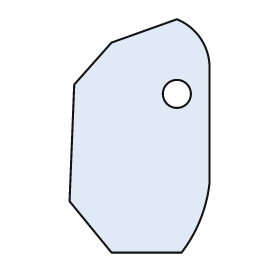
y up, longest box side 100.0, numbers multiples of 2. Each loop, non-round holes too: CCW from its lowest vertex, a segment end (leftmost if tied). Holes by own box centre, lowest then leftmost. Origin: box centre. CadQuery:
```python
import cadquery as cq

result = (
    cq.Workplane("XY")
    .moveTo(-12.0, -50.0)
    .lineTo(18.0, -50.0)
    .threePointArc((26.0, -36.0), (30.0, -20.0))
    .lineTo(30.0, 30.0)
    .threePointArc((26.0, 42.0), (16.0, 50.0))
    .lineTo(-12.0, 40.0)
    .lineTo(-28.0, 22.0)
    .lineTo(-30.0, -28.0)
    .close()
    .moveTo(16.0, 18.0)
    .circle(6.0)
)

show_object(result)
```